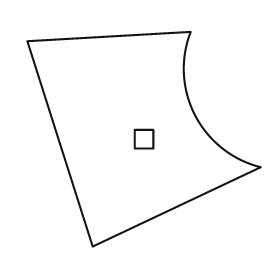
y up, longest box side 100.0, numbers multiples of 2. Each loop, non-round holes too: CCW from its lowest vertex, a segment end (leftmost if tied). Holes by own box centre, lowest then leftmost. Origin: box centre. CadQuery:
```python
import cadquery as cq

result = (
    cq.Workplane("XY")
    .moveTo(-22.0, -46.0)
    .lineTo(50.0, -12.0)
    .threePointArc((22.0, 10.0), (20.0, 46.0))
    .lineTo(-50.0, 42.0)
    .close()
    .moveTo(-4.0, -4.0)
    .lineTo(4.0, -4.0)
    .lineTo(4.0, 4.0)
    .lineTo(-4.0, 4.0)
    .close()
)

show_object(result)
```